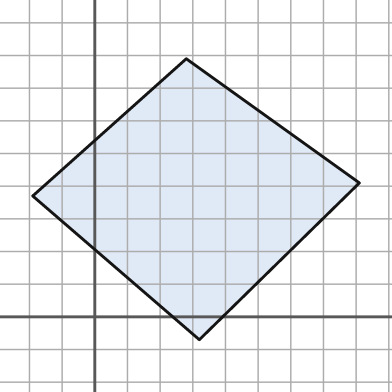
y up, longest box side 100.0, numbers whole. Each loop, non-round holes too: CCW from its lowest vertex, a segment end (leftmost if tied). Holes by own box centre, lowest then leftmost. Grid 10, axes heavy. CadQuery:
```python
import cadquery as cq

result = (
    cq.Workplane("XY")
    .moveTo(32.0, -7.0)
    .lineTo(81.0, 41.0)
    .lineTo(28.0, 79.0)
    .lineTo(-19.0, 37.0)
    .close()
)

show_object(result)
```